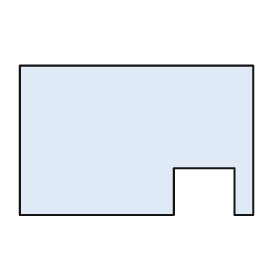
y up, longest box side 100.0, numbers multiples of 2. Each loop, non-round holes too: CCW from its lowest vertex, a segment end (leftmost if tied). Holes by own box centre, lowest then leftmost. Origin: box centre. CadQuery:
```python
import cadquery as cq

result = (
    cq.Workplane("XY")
    .moveTo(-50.0, -32.0)
    .lineTo(16.0, -32.0)
    .lineTo(16.0, -12.0)
    .lineTo(42.0, -12.0)
    .lineTo(42.0, -32.0)
    .lineTo(50.0, -32.0)
    .lineTo(50.0, 32.0)
    .lineTo(-50.0, 32.0)
    .close()
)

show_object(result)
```